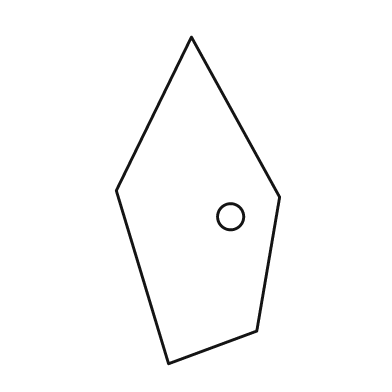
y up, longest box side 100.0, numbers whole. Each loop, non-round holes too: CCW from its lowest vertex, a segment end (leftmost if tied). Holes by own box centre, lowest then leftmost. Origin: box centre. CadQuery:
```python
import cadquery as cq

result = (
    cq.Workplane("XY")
    .moveTo(-9.0, -50.0)
    .lineTo(18.0, -40.0)
    .lineTo(25.0, 1.0)
    .lineTo(-2.0, 50.0)
    .lineTo(-25.0, 3.0)
    .close()
    .moveTo(10.0, -5.0)
    .circle(4.0)
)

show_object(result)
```